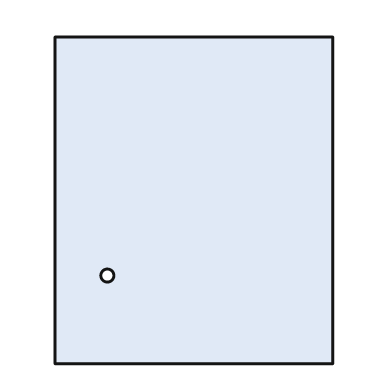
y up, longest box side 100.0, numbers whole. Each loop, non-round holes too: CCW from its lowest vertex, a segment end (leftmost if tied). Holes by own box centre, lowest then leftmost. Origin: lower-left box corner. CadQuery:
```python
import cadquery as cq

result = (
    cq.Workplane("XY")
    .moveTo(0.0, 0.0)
    .lineTo(85.0, 0.0)
    .lineTo(85.0, 100.0)
    .lineTo(0.0, 100.0)
    .close()
    .moveTo(16.0, 27.0)
    .circle(2.0)
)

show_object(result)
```